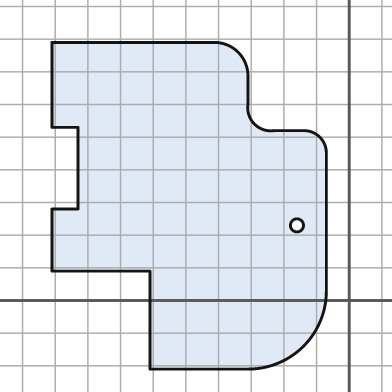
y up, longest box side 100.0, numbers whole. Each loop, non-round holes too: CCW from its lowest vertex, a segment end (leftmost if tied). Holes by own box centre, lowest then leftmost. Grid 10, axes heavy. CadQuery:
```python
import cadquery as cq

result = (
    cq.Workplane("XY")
    .moveTo(-61.0, -21.0)
    .lineTo(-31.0, -21.0)
    .threePointArc((-14.0, -14.0), (-7.0, 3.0))
    .lineTo(-7.0, 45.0)
    .threePointArc((-9.0, 50.0), (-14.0, 52.0))
    .lineTo(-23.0, 52.0)
    .threePointArc((-29.0, 54.0), (-31.0, 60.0))
    .lineTo(-31.0, 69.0)
    .threePointArc((-34.0, 76.0), (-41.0, 79.0))
    .lineTo(-91.0, 79.0)
    .lineTo(-91.0, 53.0)
    .lineTo(-83.0, 53.0)
    .lineTo(-83.0, 28.0)
    .lineTo(-91.0, 28.0)
    .lineTo(-91.0, 9.0)
    .lineTo(-61.0, 9.0)
    .close()
    .moveTo(-16.0, 23.0)
    .circle(2.0)
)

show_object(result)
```